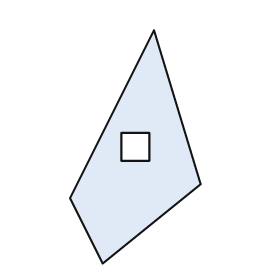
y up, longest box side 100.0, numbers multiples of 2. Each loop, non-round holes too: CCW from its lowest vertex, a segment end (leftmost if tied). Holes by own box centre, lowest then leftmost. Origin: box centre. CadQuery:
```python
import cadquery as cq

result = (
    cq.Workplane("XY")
    .moveTo(-14.0, -50.0)
    .lineTo(28.0, -16.0)
    .lineTo(8.0, 50.0)
    .lineTo(-28.0, -22.0)
    .close()
    .moveTo(-6.0, -6.0)
    .lineTo(6.0, -6.0)
    .lineTo(6.0, 6.0)
    .lineTo(-6.0, 6.0)
    .close()
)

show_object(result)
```